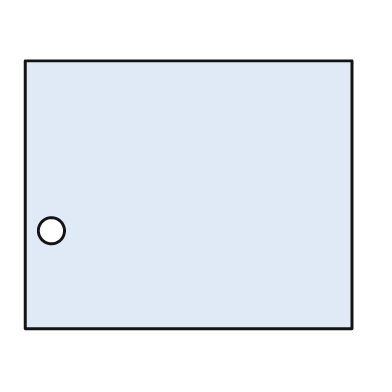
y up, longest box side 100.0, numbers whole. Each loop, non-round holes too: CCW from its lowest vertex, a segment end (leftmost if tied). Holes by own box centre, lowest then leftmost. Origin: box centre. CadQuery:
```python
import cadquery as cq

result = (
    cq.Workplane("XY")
    .moveTo(-50.0, -41.0)
    .lineTo(50.0, -41.0)
    .lineTo(50.0, 41.0)
    .lineTo(-50.0, 41.0)
    .close()
    .moveTo(-42.0, -11.0)
    .circle(4.0)
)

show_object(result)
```